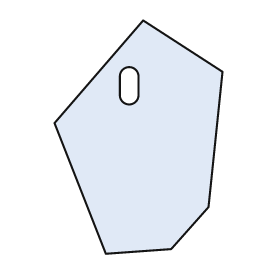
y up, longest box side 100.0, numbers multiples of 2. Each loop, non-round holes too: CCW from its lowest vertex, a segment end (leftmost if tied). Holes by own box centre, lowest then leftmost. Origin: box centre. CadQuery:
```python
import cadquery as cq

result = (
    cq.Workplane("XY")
    .moveTo(-14.0, -50.0)
    .lineTo(14.0, -48.0)
    .lineTo(30.0, -30.0)
    .lineTo(36.0, 28.0)
    .lineTo(2.0, 50.0)
    .lineTo(-36.0, 6.0)
    .close()
    .moveTo(-8.0, 18.0)
    .threePointArc((-4.0, 14.0), (0.0, 18.0))
    .lineTo(0.0, 26.0)
    .threePointArc((-4.0, 30.0), (-8.0, 26.0))
    .close()
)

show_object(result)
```